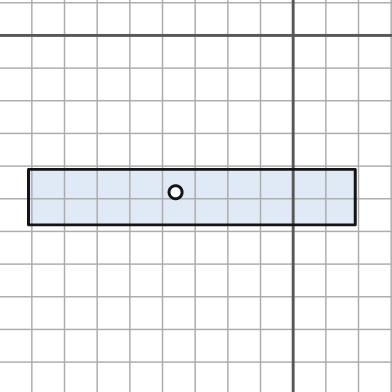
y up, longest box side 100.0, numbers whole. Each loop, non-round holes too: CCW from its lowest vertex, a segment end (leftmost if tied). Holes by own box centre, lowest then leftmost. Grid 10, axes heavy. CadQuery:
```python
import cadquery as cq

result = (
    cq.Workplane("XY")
    .moveTo(-81.0, -58.0)
    .lineTo(19.0, -58.0)
    .lineTo(19.0, -41.0)
    .lineTo(-81.0, -41.0)
    .close()
    .moveTo(-36.0, -48.0)
    .circle(2.0)
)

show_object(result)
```